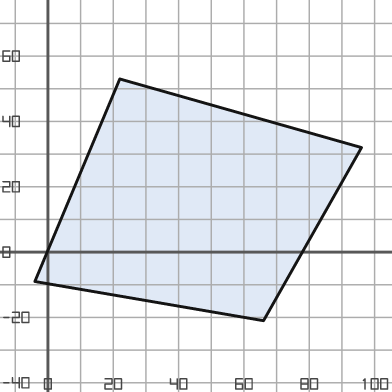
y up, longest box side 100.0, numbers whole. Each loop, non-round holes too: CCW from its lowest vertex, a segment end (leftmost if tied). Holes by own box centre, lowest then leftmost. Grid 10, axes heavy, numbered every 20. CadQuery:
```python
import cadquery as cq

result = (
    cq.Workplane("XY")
    .moveTo(66.0, -21.0)
    .lineTo(96.0, 32.0)
    .lineTo(22.0, 53.0)
    .lineTo(-4.0, -9.0)
    .close()
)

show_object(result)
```